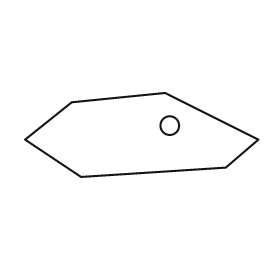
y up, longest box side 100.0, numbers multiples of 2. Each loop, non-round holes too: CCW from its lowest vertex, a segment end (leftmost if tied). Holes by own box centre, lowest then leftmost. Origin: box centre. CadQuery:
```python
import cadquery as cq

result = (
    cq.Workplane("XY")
    .moveTo(-26.0, -18.0)
    .lineTo(36.0, -14.0)
    .lineTo(50.0, -2.0)
    .lineTo(10.0, 18.0)
    .lineTo(-30.0, 14.0)
    .lineTo(-50.0, -2.0)
    .close()
    .moveTo(12.0, 4.0)
    .circle(4.0)
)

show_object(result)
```